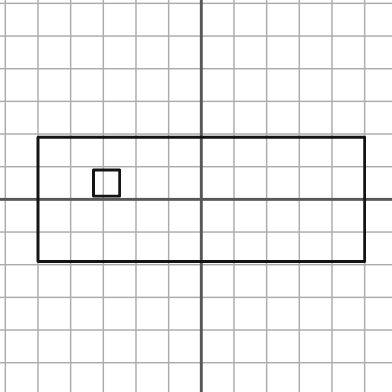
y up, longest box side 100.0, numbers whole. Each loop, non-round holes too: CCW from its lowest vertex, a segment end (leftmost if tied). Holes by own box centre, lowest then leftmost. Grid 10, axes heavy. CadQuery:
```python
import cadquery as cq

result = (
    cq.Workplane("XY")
    .moveTo(-50.0, -19.0)
    .lineTo(50.0, -19.0)
    .lineTo(50.0, 19.0)
    .lineTo(-50.0, 19.0)
    .close()
    .moveTo(-33.0, 1.0)
    .lineTo(-25.0, 1.0)
    .lineTo(-25.0, 9.0)
    .lineTo(-33.0, 9.0)
    .close()
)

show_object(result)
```